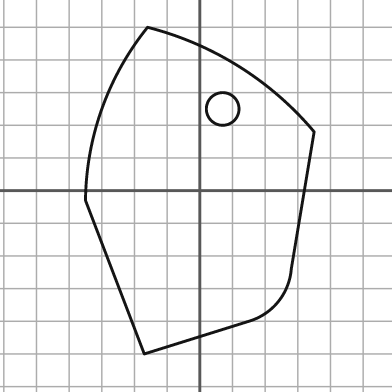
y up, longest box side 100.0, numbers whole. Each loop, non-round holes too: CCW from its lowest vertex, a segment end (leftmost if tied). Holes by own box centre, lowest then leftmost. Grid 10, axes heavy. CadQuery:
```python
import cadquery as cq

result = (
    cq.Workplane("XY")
    .moveTo(-17.0, -50.0)
    .lineTo(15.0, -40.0)
    .threePointArc((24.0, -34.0), (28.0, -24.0))
    .lineTo(35.0, 18.0)
    .threePointArc((12.0, 38.0), (-16.0, 50.0))
    .threePointArc((-30.0, 25.0), (-35.0, -3.0))
    .close()
    .moveTo(7.0, 25.0)
    .circle(5.0)
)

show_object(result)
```